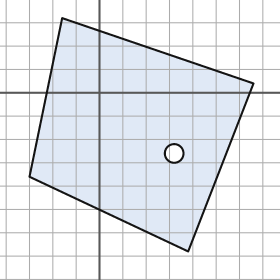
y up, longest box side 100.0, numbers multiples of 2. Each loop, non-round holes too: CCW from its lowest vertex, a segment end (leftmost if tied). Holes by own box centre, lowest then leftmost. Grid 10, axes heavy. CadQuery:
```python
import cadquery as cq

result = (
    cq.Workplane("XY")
    .moveTo(38.0, -68.0)
    .lineTo(66.0, 4.0)
    .lineTo(-16.0, 32.0)
    .lineTo(-30.0, -36.0)
    .close()
    .moveTo(32.0, -26.0)
    .circle(4.0)
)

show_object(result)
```